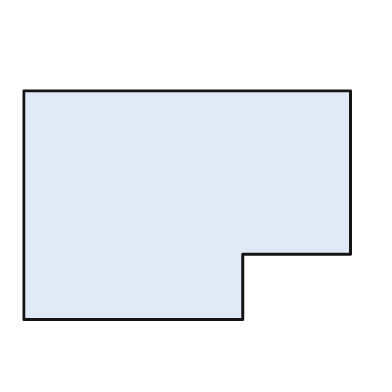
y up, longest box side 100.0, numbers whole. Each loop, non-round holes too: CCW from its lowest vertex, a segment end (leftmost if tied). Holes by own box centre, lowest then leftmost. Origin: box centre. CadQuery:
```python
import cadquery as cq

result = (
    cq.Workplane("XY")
    .moveTo(-50.0, -35.0)
    .lineTo(17.0, -35.0)
    .lineTo(17.0, -15.0)
    .lineTo(50.0, -15.0)
    .lineTo(50.0, 35.0)
    .lineTo(-50.0, 35.0)
    .close()
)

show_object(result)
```